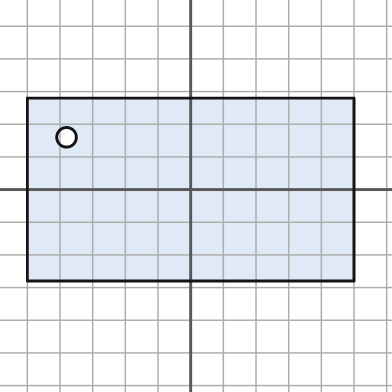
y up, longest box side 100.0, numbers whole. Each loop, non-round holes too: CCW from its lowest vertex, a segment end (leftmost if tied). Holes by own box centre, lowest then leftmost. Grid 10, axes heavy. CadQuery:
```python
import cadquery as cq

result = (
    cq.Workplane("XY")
    .moveTo(-50.0, -28.0)
    .lineTo(50.0, -28.0)
    .lineTo(50.0, 28.0)
    .lineTo(-50.0, 28.0)
    .close()
    .moveTo(-38.0, 16.0)
    .circle(3.0)
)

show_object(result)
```